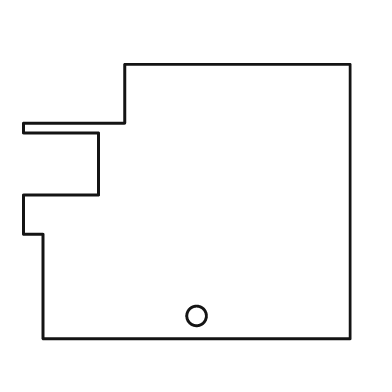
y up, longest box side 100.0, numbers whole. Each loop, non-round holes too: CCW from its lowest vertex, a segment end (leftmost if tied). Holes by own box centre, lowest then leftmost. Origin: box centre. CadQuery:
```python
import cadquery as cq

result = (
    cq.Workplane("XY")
    .moveTo(-44.0, -42.0)
    .lineTo(50.0, -42.0)
    .lineTo(50.0, 42.0)
    .lineTo(-19.0, 42.0)
    .lineTo(-19.0, 24.0)
    .lineTo(-50.0, 24.0)
    .lineTo(-50.0, 21.0)
    .lineTo(-27.0, 21.0)
    .lineTo(-27.0, 2.0)
    .lineTo(-50.0, 2.0)
    .lineTo(-50.0, -10.0)
    .lineTo(-44.0, -10.0)
    .close()
    .moveTo(3.0, -35.0)
    .circle(3.0)
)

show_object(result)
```